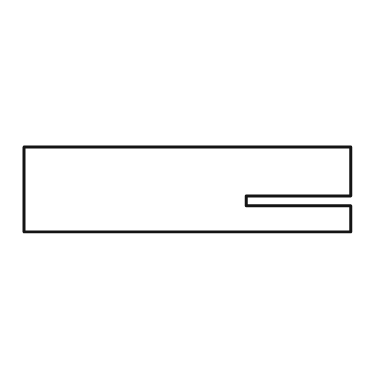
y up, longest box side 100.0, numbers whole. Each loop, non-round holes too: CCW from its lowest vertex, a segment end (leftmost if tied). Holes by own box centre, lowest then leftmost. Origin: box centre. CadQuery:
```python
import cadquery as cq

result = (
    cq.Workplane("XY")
    .moveTo(-50.0, -13.0)
    .lineTo(50.0, -13.0)
    .lineTo(50.0, -5.0)
    .lineTo(18.0, -5.0)
    .lineTo(18.0, -2.0)
    .lineTo(50.0, -2.0)
    .lineTo(50.0, 13.0)
    .lineTo(-50.0, 13.0)
    .close()
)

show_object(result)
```